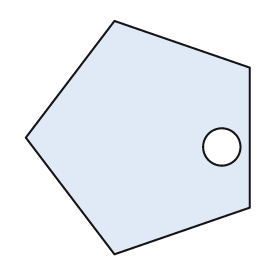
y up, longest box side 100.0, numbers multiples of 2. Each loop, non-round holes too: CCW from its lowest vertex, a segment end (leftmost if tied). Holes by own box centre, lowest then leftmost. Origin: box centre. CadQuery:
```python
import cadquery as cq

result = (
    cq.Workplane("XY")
    .moveTo(-10.0, -50.0)
    .lineTo(48.0, -30.0)
    .lineTo(48.0, 30.0)
    .lineTo(-10.0, 50.0)
    .lineTo(-48.0, 0.0)
    .close()
    .moveTo(36.0, -4.0)
    .circle(8.0)
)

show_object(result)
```